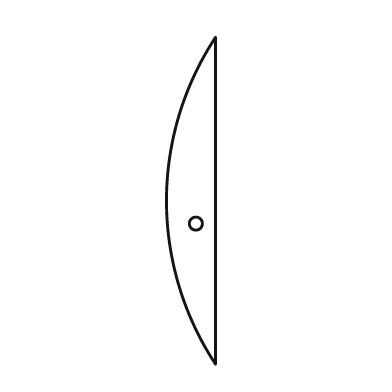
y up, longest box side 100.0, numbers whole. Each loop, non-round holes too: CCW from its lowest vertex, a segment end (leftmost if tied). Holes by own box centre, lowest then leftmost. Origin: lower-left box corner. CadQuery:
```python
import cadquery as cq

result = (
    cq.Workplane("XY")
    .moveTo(15.0, 0.0)
    .lineTo(15.0, 100.0)
    .threePointArc((0.0, 50.0), (15.0, 0.0))
    .close()
    .moveTo(9.0, 43.0)
    .circle(2.0)
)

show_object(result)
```